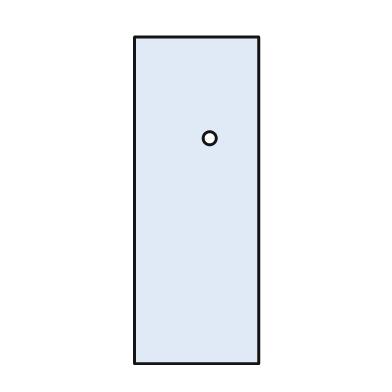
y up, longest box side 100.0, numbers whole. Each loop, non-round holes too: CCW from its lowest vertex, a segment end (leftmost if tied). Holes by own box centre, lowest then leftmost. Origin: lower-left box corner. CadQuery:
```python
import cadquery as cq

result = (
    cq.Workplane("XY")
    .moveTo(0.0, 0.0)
    .lineTo(38.0, 0.0)
    .lineTo(38.0, 100.0)
    .lineTo(0.0, 100.0)
    .close()
    .moveTo(23.0, 69.0)
    .circle(2.0)
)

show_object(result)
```